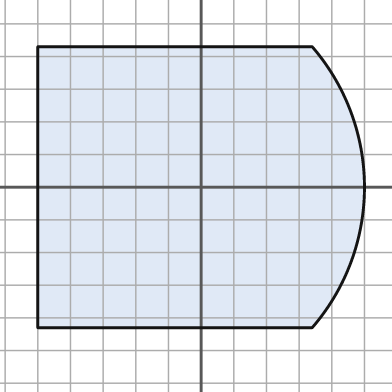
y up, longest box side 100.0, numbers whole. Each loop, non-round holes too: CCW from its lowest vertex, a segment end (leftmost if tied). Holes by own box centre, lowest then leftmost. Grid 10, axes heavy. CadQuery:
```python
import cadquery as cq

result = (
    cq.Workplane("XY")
    .moveTo(-50.0, -43.0)
    .lineTo(34.0, -43.0)
    .threePointArc((50.0, 0.0), (34.0, 43.0))
    .lineTo(-50.0, 43.0)
    .close()
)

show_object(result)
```